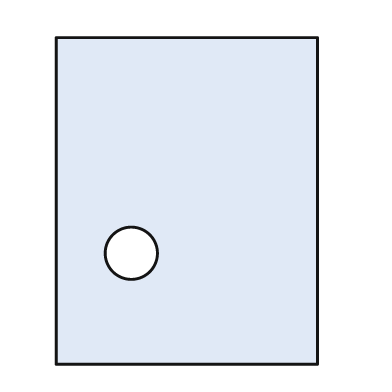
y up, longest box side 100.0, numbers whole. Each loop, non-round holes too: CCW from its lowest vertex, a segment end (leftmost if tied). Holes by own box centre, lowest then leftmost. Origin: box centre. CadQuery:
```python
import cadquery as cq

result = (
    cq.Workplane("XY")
    .moveTo(-40.0, -50.0)
    .lineTo(40.0, -50.0)
    .lineTo(40.0, 50.0)
    .lineTo(-40.0, 50.0)
    .close()
    .moveTo(-17.0, -16.0)
    .circle(8.0)
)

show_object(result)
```